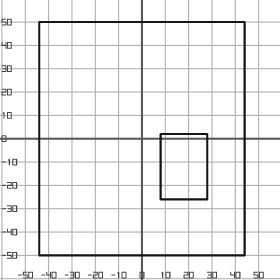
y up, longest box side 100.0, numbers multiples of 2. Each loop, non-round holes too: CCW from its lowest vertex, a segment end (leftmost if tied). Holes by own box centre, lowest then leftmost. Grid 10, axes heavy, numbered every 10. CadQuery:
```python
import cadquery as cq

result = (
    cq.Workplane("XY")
    .moveTo(-44.0, -50.0)
    .lineTo(44.0, -50.0)
    .lineTo(44.0, 50.0)
    .lineTo(-44.0, 50.0)
    .close()
    .moveTo(8.0, -26.0)
    .lineTo(28.0, -26.0)
    .lineTo(28.0, 2.0)
    .lineTo(8.0, 2.0)
    .close()
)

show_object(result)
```